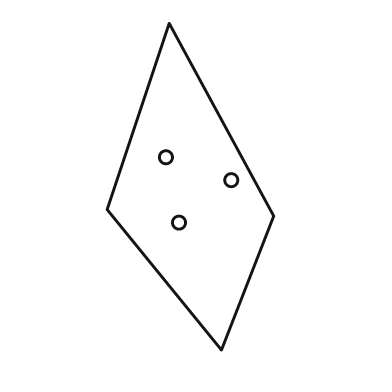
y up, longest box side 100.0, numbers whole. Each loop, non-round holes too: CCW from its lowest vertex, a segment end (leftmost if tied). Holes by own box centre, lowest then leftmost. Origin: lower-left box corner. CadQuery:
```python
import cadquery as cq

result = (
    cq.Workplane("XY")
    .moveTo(35.0, 0.0)
    .lineTo(51.0, 41.0)
    .lineTo(19.0, 100.0)
    .lineTo(0.0, 43.0)
    .close()
    .moveTo(22.0, 39.0)
    .circle(2.0)
    .moveTo(38.0, 52.0)
    .circle(2.0)
    .moveTo(18.0, 59.0)
    .circle(2.0)
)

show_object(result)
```